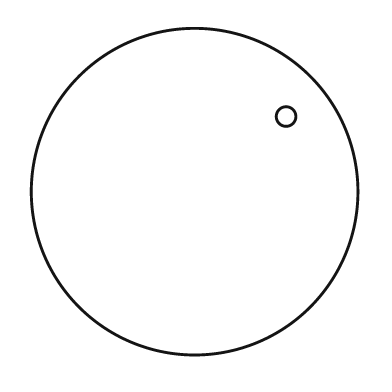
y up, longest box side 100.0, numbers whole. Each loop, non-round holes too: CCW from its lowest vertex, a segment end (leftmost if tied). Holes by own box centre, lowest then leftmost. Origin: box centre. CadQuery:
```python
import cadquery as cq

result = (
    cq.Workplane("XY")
    .moveTo(0.0, 0.0)
    .circle(50.0)
    .moveTo(28.0, 23.0)
    .circle(3.0)
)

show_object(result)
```